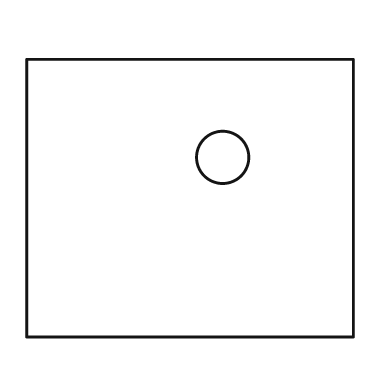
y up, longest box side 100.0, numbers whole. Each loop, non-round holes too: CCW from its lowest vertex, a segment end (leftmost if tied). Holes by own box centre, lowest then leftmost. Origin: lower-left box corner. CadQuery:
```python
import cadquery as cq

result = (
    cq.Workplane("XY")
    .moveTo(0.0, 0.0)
    .lineTo(100.0, 0.0)
    .lineTo(100.0, 85.0)
    .lineTo(0.0, 85.0)
    .close()
    .moveTo(60.0, 55.0)
    .circle(8.0)
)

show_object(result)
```